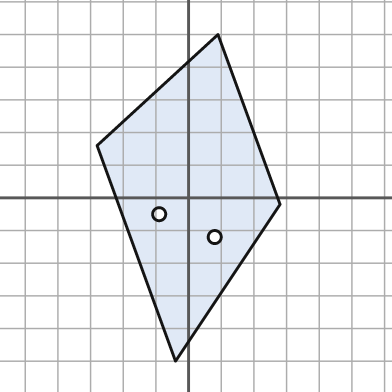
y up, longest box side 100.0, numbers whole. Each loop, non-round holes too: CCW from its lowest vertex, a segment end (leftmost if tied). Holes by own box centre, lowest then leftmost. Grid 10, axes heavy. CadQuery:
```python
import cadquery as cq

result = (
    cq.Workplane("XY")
    .moveTo(-4.0, -50.0)
    .lineTo(28.0, -2.0)
    .lineTo(9.0, 50.0)
    .lineTo(-28.0, 16.0)
    .close()
    .moveTo(8.0, -12.0)
    .circle(2.0)
    .moveTo(-9.0, -5.0)
    .circle(2.0)
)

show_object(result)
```